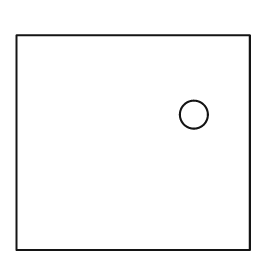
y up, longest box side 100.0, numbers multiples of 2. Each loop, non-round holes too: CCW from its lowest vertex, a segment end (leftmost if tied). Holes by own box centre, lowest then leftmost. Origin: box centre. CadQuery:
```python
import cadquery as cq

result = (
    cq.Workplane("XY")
    .moveTo(-50.0, -46.0)
    .lineTo(50.0, -46.0)
    .lineTo(50.0, 46.0)
    .lineTo(-50.0, 46.0)
    .close()
    .moveTo(26.0, 12.0)
    .circle(6.0)
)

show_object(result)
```